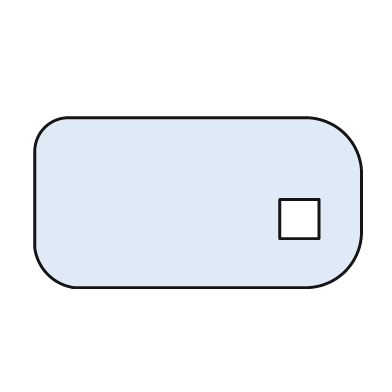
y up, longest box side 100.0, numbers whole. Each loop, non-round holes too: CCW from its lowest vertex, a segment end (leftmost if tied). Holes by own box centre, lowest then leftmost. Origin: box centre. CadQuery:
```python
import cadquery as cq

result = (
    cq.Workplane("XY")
    .moveTo(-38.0, -26.0)
    .lineTo(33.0, -26.0)
    .threePointArc((45.0, -21.0), (50.0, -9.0))
    .lineTo(50.0, 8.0)
    .threePointArc((45.0, 21.0), (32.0, 26.0))
    .lineTo(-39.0, 26.0)
    .threePointArc((-47.0, 23.0), (-50.0, 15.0))
    .lineTo(-50.0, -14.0)
    .threePointArc((-46.0, -22.0), (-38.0, -26.0))
    .close()
    .moveTo(25.0, -11.0)
    .lineTo(37.0, -11.0)
    .lineTo(37.0, 1.0)
    .lineTo(25.0, 1.0)
    .close()
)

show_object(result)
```